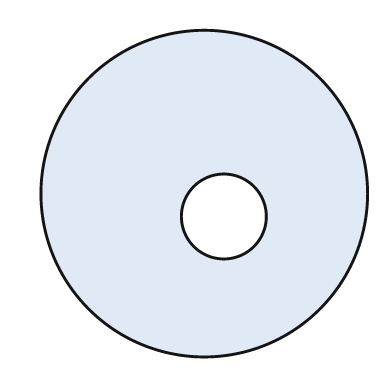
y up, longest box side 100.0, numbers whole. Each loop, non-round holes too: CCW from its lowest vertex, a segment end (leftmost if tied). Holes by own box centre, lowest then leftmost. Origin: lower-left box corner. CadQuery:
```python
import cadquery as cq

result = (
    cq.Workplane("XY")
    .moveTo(50.0, 50.0)
    .circle(50.0)
    .moveTo(56.0, 43.0)
    .circle(13.0)
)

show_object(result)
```